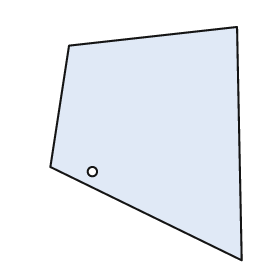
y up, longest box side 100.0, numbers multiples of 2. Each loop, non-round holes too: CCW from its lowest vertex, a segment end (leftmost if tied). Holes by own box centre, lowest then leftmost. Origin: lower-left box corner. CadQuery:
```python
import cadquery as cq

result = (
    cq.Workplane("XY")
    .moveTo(82.0, 0.0)
    .lineTo(80.0, 100.0)
    .lineTo(8.0, 92.0)
    .lineTo(0.0, 40.0)
    .close()
    .moveTo(18.0, 38.0)
    .circle(2.0)
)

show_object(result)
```